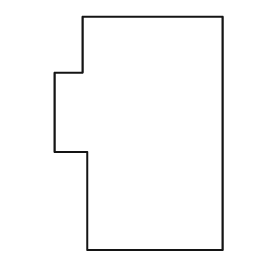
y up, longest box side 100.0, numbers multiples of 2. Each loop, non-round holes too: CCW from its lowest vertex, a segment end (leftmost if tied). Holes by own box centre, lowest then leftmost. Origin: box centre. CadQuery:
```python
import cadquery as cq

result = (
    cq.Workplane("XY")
    .moveTo(-22.0, -50.0)
    .lineTo(36.0, -50.0)
    .lineTo(36.0, 50.0)
    .lineTo(-24.0, 50.0)
    .lineTo(-24.0, 26.0)
    .lineTo(-36.0, 26.0)
    .lineTo(-36.0, -8.0)
    .lineTo(-22.0, -8.0)
    .close()
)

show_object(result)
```